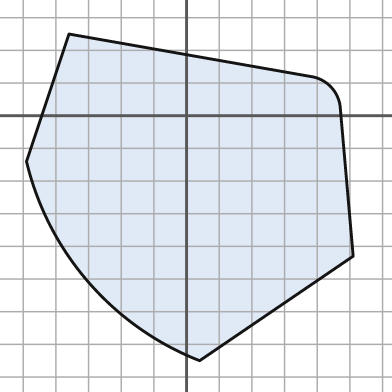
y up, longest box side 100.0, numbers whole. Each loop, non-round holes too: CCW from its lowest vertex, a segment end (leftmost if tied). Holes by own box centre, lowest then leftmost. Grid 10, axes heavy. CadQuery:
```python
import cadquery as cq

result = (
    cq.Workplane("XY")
    .moveTo(4.0, -75.0)
    .lineTo(51.0, -43.0)
    .lineTo(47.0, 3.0)
    .threePointArc((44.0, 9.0), (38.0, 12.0))
    .lineTo(-36.0, 25.0)
    .lineTo(-49.0, -14.0)
    .threePointArc((-30.0, -51.0), (4.0, -75.0))
    .close()
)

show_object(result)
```